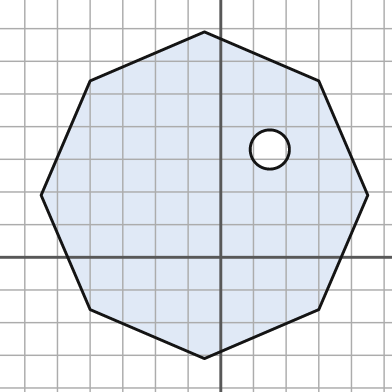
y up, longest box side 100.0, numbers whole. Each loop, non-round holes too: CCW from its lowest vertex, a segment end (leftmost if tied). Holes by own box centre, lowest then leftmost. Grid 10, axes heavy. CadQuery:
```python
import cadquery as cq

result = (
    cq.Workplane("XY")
    .moveTo(-5.0, -31.0)
    .lineTo(30.0, -16.0)
    .lineTo(45.0, 19.0)
    .lineTo(30.0, 54.0)
    .lineTo(-5.0, 69.0)
    .lineTo(-40.0, 54.0)
    .lineTo(-55.0, 19.0)
    .lineTo(-40.0, -16.0)
    .close()
    .moveTo(15.0, 33.0)
    .circle(6.0)
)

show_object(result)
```